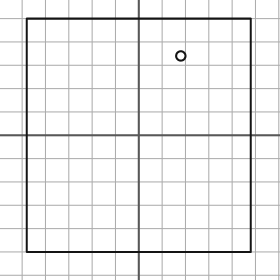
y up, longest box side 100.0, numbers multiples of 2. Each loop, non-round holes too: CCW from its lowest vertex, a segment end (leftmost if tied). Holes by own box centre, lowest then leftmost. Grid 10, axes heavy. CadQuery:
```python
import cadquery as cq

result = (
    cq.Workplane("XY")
    .moveTo(-48.0, -50.0)
    .lineTo(48.0, -50.0)
    .lineTo(48.0, 50.0)
    .lineTo(-48.0, 50.0)
    .close()
    .moveTo(18.0, 34.0)
    .circle(2.0)
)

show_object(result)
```